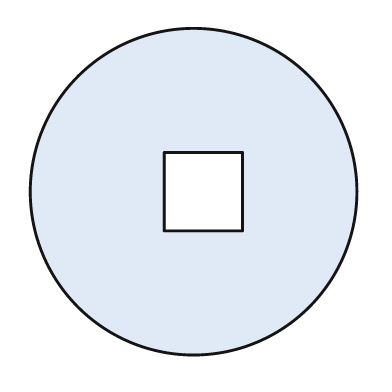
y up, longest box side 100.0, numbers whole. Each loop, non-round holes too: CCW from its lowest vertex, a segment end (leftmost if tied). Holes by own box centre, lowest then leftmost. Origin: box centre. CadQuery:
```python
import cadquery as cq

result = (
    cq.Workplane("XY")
    .moveTo(0.0, 0.0)
    .circle(50.0)
    .moveTo(-9.0, -12.0)
    .lineTo(15.0, -12.0)
    .lineTo(15.0, 12.0)
    .lineTo(-9.0, 12.0)
    .close()
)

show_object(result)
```